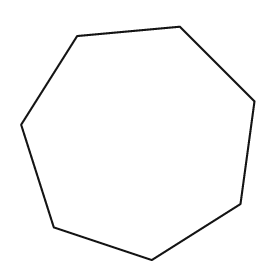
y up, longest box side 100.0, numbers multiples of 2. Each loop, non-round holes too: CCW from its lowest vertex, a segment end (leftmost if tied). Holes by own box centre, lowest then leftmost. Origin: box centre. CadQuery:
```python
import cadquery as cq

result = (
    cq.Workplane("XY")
    .moveTo(6.0, -50.0)
    .lineTo(44.0, -26.0)
    .lineTo(50.0, 18.0)
    .lineTo(18.0, 50.0)
    .lineTo(-26.0, 46.0)
    .lineTo(-50.0, 8.0)
    .lineTo(-36.0, -36.0)
    .close()
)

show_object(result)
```